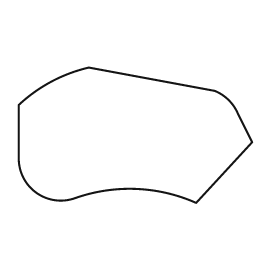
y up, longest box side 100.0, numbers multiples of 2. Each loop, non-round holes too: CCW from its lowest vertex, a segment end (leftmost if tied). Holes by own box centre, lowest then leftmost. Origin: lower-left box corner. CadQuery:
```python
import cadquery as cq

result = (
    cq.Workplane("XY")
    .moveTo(76.0, 0.0)
    .lineTo(100.0, 26.0)
    .lineTo(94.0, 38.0)
    .threePointArc((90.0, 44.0), (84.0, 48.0))
    .lineTo(30.0, 58.0)
    .threePointArc((14.0, 52.0), (0.0, 42.0))
    .lineTo(0.0, 18.0)
    .threePointArc((8.0, 4.0), (24.0, 2.0))
    .threePointArc((50.0, 6.0), (76.0, 0.0))
    .close()
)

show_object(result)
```